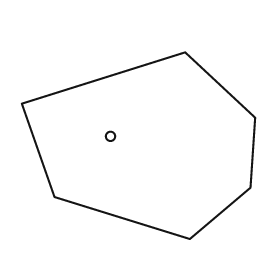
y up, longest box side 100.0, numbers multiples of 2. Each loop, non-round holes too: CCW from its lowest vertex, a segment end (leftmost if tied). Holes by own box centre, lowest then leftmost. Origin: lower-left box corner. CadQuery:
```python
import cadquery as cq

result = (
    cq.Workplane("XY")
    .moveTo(72.0, 0.0)
    .lineTo(98.0, 22.0)
    .lineTo(100.0, 52.0)
    .lineTo(70.0, 80.0)
    .lineTo(0.0, 58.0)
    .lineTo(14.0, 18.0)
    .close()
    .moveTo(38.0, 44.0)
    .circle(2.0)
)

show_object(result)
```